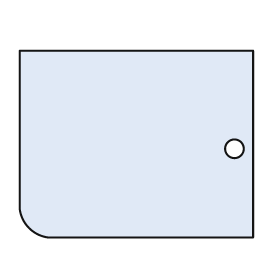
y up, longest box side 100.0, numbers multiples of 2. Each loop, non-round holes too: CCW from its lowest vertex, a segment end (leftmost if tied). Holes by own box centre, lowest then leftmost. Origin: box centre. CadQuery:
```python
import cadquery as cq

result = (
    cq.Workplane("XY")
    .moveTo(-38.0, -40.0)
    .lineTo(50.0, -40.0)
    .lineTo(50.0, 40.0)
    .lineTo(-50.0, 40.0)
    .lineTo(-50.0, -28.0)
    .threePointArc((-46.0, -36.0), (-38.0, -40.0))
    .close()
    .moveTo(42.0, -2.0)
    .circle(4.0)
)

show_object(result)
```